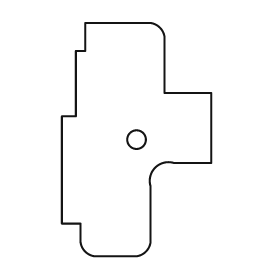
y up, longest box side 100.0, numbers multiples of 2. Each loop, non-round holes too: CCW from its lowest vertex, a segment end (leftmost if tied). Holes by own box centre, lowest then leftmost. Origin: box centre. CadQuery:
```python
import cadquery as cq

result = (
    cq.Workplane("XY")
    .moveTo(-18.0, -50.0)
    .lineTo(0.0, -50.0)
    .threePointArc((4.0, -48.0), (6.0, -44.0))
    .lineTo(6.0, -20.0)
    .threePointArc((8.0, -12.0), (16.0, -10.0))
    .lineTo(32.0, -10.0)
    .lineTo(32.0, 20.0)
    .lineTo(12.0, 20.0)
    .lineTo(12.0, 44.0)
    .threePointArc((10.0, 48.0), (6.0, 50.0))
    .lineTo(-22.0, 50.0)
    .lineTo(-22.0, 38.0)
    .lineTo(-26.0, 38.0)
    .lineTo(-26.0, 10.0)
    .lineTo(-32.0, 10.0)
    .lineTo(-32.0, -36.0)
    .lineTo(-24.0, -36.0)
    .lineTo(-24.0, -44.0)
    .threePointArc((-22.0, -48.0), (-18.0, -50.0))
    .close()
    .moveTo(0.0, 0.0)
    .circle(4.0)
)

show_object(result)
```